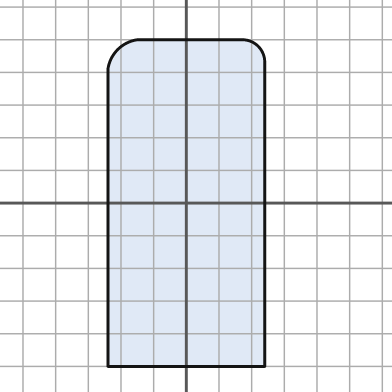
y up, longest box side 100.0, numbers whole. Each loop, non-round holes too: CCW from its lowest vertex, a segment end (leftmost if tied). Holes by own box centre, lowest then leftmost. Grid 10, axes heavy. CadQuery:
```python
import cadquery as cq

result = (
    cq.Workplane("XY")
    .moveTo(-24.0, -50.0)
    .lineTo(24.0, -50.0)
    .lineTo(24.0, 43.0)
    .threePointArc((22.0, 48.0), (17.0, 50.0))
    .lineTo(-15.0, 50.0)
    .threePointArc((-21.0, 47.0), (-24.0, 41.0))
    .close()
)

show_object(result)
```